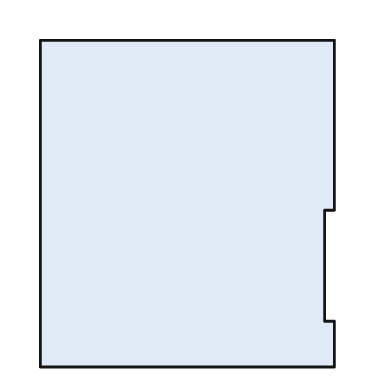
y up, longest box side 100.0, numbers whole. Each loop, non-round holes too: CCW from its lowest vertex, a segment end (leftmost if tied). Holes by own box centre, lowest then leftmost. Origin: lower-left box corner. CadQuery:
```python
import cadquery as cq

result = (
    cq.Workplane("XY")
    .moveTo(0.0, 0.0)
    .lineTo(90.0, 0.0)
    .lineTo(90.0, 14.0)
    .lineTo(87.0, 14.0)
    .lineTo(87.0, 48.0)
    .lineTo(90.0, 48.0)
    .lineTo(90.0, 100.0)
    .lineTo(0.0, 100.0)
    .close()
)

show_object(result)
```